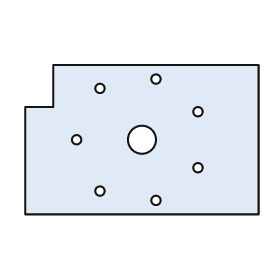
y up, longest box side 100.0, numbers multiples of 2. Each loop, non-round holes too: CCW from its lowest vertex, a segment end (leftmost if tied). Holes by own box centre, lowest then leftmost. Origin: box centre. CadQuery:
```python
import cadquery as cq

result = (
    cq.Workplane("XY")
    .moveTo(-50.0, -32.0)
    .lineTo(50.0, -32.0)
    .lineTo(50.0, 32.0)
    .lineTo(-38.0, 32.0)
    .lineTo(-38.0, 14.0)
    .lineTo(-50.0, 14.0)
    .close()
    .moveTo(6.0, -26.0)
    .circle(2.0)
    .moveTo(-18.0, -22.0)
    .circle(2.0)
    .moveTo(24.0, -12.0)
    .circle(2.0)
    .moveTo(-28.0, 0.0)
    .circle(2.0)
    .moveTo(0.0, 0.0)
    .circle(6.0)
    .moveTo(24.0, 12.0)
    .circle(2.0)
    .moveTo(-18.0, 22.0)
    .circle(2.0)
    .moveTo(6.0, 26.0)
    .circle(2.0)
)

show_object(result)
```